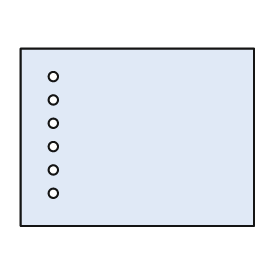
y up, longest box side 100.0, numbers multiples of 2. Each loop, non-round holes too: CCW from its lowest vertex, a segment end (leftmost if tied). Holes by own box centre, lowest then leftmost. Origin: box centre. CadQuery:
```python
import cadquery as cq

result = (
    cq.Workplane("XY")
    .moveTo(-50.0, -38.0)
    .lineTo(50.0, -38.0)
    .lineTo(50.0, 38.0)
    .lineTo(-50.0, 38.0)
    .close()
    .moveTo(-36.0, -24.0)
    .circle(2.0)
    .moveTo(-36.0, -14.0)
    .circle(2.0)
    .moveTo(-36.0, -4.0)
    .circle(2.0)
    .moveTo(-36.0, 6.0)
    .circle(2.0)
    .moveTo(-36.0, 16.0)
    .circle(2.0)
    .moveTo(-36.0, 26.0)
    .circle(2.0)
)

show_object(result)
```